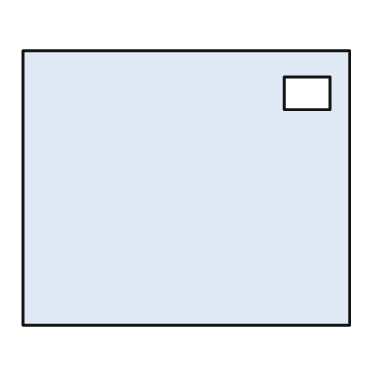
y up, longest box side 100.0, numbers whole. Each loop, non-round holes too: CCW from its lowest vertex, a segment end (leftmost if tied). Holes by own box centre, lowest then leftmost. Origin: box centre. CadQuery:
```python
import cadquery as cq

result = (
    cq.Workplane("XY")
    .moveTo(-50.0, -42.0)
    .lineTo(50.0, -42.0)
    .lineTo(50.0, 42.0)
    .lineTo(-50.0, 42.0)
    .close()
    .moveTo(30.0, 24.0)
    .lineTo(44.0, 24.0)
    .lineTo(44.0, 34.0)
    .lineTo(30.0, 34.0)
    .close()
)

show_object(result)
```